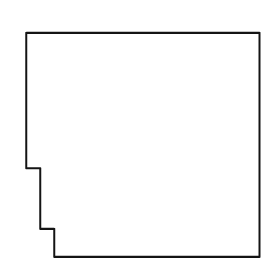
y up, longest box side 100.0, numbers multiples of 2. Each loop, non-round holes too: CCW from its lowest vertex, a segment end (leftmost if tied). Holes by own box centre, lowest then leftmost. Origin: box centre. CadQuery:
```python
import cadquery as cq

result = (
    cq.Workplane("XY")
    .moveTo(-38.0, -48.0)
    .lineTo(50.0, -48.0)
    .lineTo(50.0, 48.0)
    .lineTo(-50.0, 48.0)
    .lineTo(-50.0, -10.0)
    .lineTo(-44.0, -10.0)
    .lineTo(-44.0, -36.0)
    .lineTo(-38.0, -36.0)
    .close()
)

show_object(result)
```